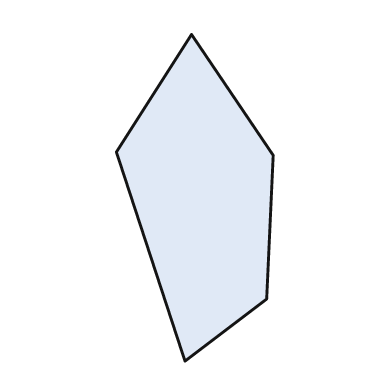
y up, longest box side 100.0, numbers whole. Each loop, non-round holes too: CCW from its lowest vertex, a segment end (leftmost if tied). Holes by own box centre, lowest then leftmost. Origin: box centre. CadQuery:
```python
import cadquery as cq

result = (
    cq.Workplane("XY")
    .moveTo(-3.0, -50.0)
    .lineTo(22.0, -31.0)
    .lineTo(24.0, 13.0)
    .lineTo(-1.0, 50.0)
    .lineTo(-24.0, 14.0)
    .close()
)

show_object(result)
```